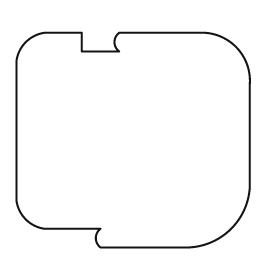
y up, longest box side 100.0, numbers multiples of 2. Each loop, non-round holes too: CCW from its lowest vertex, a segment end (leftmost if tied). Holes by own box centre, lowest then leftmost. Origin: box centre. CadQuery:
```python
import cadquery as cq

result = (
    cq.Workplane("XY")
    .moveTo(-14.0, -46.0)
    .lineTo(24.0, -46.0)
    .threePointArc((42.0, -38.0), (50.0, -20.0))
    .lineTo(50.0, 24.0)
    .threePointArc((44.0, 40.0), (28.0, 46.0))
    .lineTo(-6.0, 46.0)
    .threePointArc((-8.0, 42.0), (-6.0, 38.0))
    .lineTo(-22.0, 38.0)
    .lineTo(-22.0, 46.0)
    .lineTo(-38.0, 46.0)
    .threePointArc((-46.0, 42.0), (-50.0, 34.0))
    .lineTo(-50.0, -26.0)
    .threePointArc((-46.0, -34.0), (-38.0, -38.0))
    .lineTo(-14.0, -38.0)
    .threePointArc((-16.0, -42.0), (-14.0, -46.0))
    .close()
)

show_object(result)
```